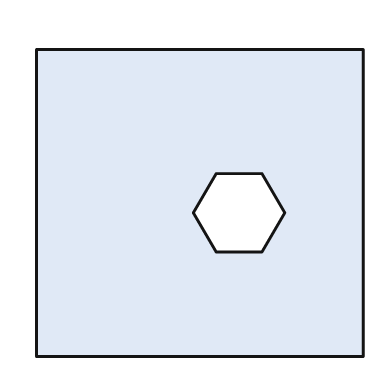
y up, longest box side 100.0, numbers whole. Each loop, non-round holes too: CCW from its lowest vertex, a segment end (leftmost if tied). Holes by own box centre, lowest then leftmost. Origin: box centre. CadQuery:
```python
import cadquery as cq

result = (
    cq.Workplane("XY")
    .moveTo(-50.0, -47.0)
    .lineTo(50.0, -47.0)
    .lineTo(50.0, 47.0)
    .lineTo(-50.0, 47.0)
    .close()
    .moveTo(5.0, -15.0)
    .lineTo(19.0, -15.0)
    .lineTo(26.0, -3.0)
    .lineTo(19.0, 9.0)
    .lineTo(5.0, 9.0)
    .lineTo(-2.0, -3.0)
    .close()
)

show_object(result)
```